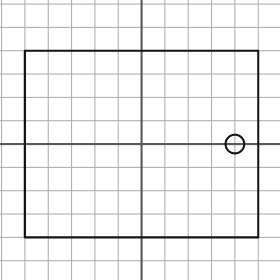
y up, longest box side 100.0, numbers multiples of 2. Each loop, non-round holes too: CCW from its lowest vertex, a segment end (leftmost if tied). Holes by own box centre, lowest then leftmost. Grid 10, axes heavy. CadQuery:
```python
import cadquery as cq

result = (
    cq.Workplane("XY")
    .moveTo(-50.0, -40.0)
    .lineTo(50.0, -40.0)
    .lineTo(50.0, 40.0)
    .lineTo(-50.0, 40.0)
    .close()
    .moveTo(40.0, 0.0)
    .circle(4.0)
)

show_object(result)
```